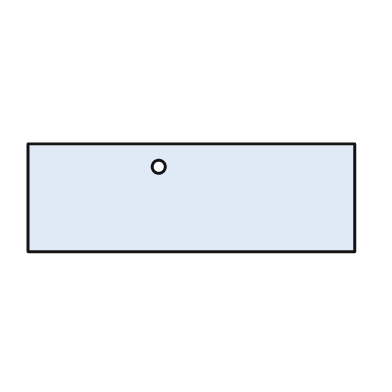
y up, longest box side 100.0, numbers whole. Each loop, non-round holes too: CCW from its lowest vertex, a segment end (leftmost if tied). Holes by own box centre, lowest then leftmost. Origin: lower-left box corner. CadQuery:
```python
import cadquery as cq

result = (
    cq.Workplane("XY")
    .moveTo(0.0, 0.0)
    .lineTo(100.0, 0.0)
    .lineTo(100.0, 33.0)
    .lineTo(0.0, 33.0)
    .close()
    .moveTo(40.0, 26.0)
    .circle(2.0)
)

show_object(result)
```